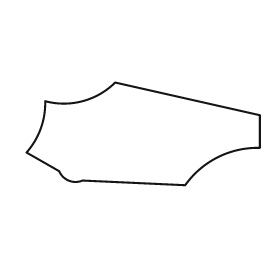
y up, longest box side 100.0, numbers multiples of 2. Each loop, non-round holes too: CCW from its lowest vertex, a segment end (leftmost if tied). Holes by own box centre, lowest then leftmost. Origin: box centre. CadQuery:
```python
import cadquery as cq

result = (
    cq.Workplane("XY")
    .moveTo(18.0, -22.0)
    .threePointArc((32.0, -10.0), (50.0, -6.0))
    .lineTo(50.0, 8.0)
    .lineTo(-12.0, 22.0)
    .threePointArc((-26.0, 14.0), (-42.0, 14.0))
    .threePointArc((-44.0, 2.0), (-50.0, -8.0))
    .lineTo(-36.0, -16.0)
    .threePointArc((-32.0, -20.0), (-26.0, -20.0))
    .close()
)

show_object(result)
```